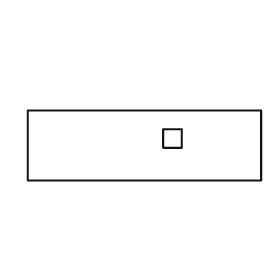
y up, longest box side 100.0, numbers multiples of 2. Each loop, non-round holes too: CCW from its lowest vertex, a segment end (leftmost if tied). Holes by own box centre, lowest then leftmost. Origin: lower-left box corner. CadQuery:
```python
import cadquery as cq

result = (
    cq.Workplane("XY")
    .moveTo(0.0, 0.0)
    .lineTo(100.0, 0.0)
    .lineTo(100.0, 30.0)
    .lineTo(0.0, 30.0)
    .close()
    .moveTo(58.0, 14.0)
    .lineTo(66.0, 14.0)
    .lineTo(66.0, 22.0)
    .lineTo(58.0, 22.0)
    .close()
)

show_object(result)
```